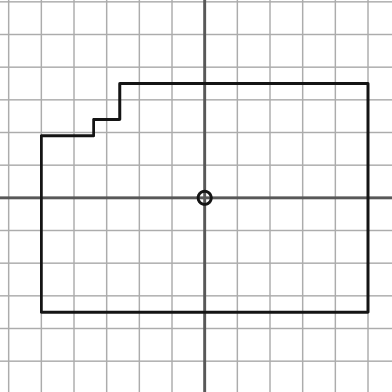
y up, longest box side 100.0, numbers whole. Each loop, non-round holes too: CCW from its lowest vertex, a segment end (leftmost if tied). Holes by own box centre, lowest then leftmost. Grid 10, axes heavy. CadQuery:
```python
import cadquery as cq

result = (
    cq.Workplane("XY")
    .moveTo(-50.0, -35.0)
    .lineTo(50.0, -35.0)
    .lineTo(50.0, 35.0)
    .lineTo(-26.0, 35.0)
    .lineTo(-26.0, 24.0)
    .lineTo(-34.0, 24.0)
    .lineTo(-34.0, 19.0)
    .lineTo(-50.0, 19.0)
    .close()
    .moveTo(0.0, 0.0)
    .circle(2.0)
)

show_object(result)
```